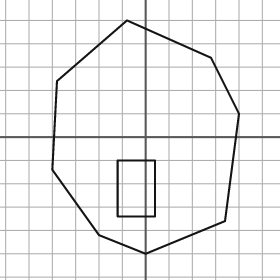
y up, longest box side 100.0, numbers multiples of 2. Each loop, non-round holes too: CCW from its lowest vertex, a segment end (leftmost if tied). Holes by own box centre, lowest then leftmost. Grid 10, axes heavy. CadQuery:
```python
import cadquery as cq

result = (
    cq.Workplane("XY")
    .moveTo(0.0, -50.0)
    .lineTo(34.0, -36.0)
    .lineTo(40.0, 10.0)
    .lineTo(28.0, 34.0)
    .lineTo(-8.0, 50.0)
    .lineTo(-38.0, 24.0)
    .lineTo(-40.0, -14.0)
    .lineTo(-20.0, -42.0)
    .close()
    .moveTo(-12.0, -34.0)
    .lineTo(4.0, -34.0)
    .lineTo(4.0, -10.0)
    .lineTo(-12.0, -10.0)
    .close()
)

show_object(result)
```